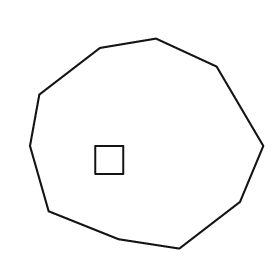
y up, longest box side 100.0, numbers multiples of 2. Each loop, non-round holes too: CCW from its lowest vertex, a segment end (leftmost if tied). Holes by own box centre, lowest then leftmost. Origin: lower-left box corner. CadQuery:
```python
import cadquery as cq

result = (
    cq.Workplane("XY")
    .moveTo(64.0, 0.0)
    .lineTo(90.0, 20.0)
    .lineTo(100.0, 44.0)
    .lineTo(80.0, 78.0)
    .lineTo(54.0, 90.0)
    .lineTo(30.0, 86.0)
    .lineTo(4.0, 66.0)
    .lineTo(0.0, 44.0)
    .lineTo(8.0, 16.0)
    .lineTo(38.0, 4.0)
    .close()
    .moveTo(28.0, 32.0)
    .lineTo(40.0, 32.0)
    .lineTo(40.0, 44.0)
    .lineTo(28.0, 44.0)
    .close()
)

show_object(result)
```